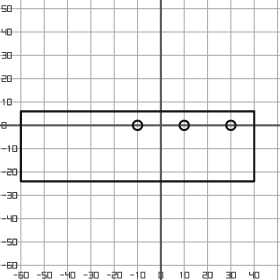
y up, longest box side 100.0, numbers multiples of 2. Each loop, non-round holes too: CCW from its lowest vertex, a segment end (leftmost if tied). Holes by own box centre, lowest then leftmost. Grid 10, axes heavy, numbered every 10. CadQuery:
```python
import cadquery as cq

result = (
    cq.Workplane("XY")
    .moveTo(-60.0, -24.0)
    .lineTo(40.0, -24.0)
    .lineTo(40.0, 6.0)
    .lineTo(-60.0, 6.0)
    .close()
    .moveTo(-10.0, 0.0)
    .circle(2.0)
    .moveTo(10.0, 0.0)
    .circle(2.0)
    .moveTo(30.0, 0.0)
    .circle(2.0)
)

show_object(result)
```